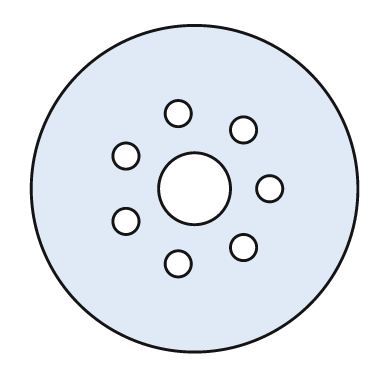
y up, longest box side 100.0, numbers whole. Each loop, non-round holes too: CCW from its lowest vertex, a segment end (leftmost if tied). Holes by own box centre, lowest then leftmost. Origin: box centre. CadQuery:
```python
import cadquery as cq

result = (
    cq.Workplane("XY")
    .moveTo(0.0, 0.0)
    .circle(50.0)
    .moveTo(-5.0, -23.0)
    .circle(4.0)
    .moveTo(15.0, -18.0)
    .circle(4.0)
    .moveTo(-21.0, -10.0)
    .circle(4.0)
    .moveTo(0.0, 0.0)
    .circle(11.0)
    .moveTo(23.0, 0.0)
    .circle(4.0)
    .moveTo(-21.0, 10.0)
    .circle(4.0)
    .moveTo(15.0, 18.0)
    .circle(4.0)
    .moveTo(-5.0, 23.0)
    .circle(4.0)
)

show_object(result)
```